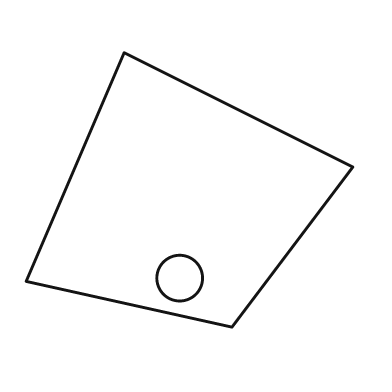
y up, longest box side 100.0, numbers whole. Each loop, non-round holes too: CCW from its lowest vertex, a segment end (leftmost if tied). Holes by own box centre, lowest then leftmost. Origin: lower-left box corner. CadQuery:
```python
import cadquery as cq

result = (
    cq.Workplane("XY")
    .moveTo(63.0, 0.0)
    .lineTo(100.0, 49.0)
    .lineTo(30.0, 84.0)
    .lineTo(0.0, 14.0)
    .close()
    .moveTo(47.0, 15.0)
    .circle(7.0)
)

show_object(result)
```